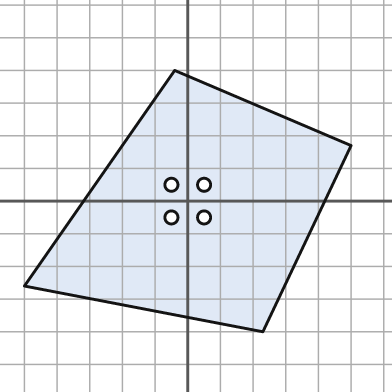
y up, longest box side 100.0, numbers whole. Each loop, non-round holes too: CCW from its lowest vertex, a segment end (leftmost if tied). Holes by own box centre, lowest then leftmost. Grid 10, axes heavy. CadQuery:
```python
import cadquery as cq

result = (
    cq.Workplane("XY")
    .moveTo(23.0, -40.0)
    .lineTo(50.0, 17.0)
    .lineTo(-4.0, 40.0)
    .lineTo(-50.0, -26.0)
    .close()
    .moveTo(-5.0, -5.0)
    .circle(2.0)
    .moveTo(5.0, -5.0)
    .circle(2.0)
    .moveTo(-5.0, 5.0)
    .circle(2.0)
    .moveTo(5.0, 5.0)
    .circle(2.0)
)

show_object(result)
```